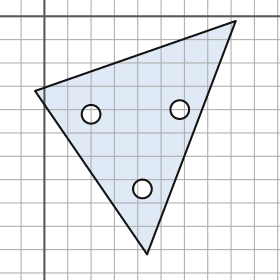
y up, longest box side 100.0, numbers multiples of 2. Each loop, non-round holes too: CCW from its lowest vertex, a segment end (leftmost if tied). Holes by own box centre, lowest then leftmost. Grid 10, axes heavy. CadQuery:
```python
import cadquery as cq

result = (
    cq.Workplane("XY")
    .moveTo(44.0, -102.0)
    .lineTo(82.0, -2.0)
    .lineTo(-4.0, -32.0)
    .close()
    .moveTo(42.0, -74.0)
    .circle(4.0)
    .moveTo(20.0, -42.0)
    .circle(4.0)
    .moveTo(58.0, -40.0)
    .circle(4.0)
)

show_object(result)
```